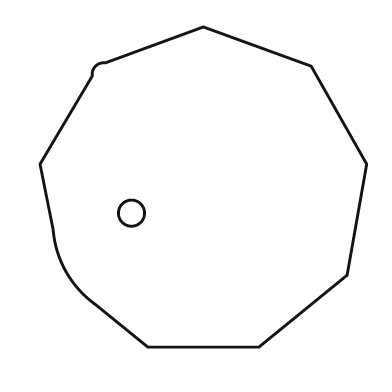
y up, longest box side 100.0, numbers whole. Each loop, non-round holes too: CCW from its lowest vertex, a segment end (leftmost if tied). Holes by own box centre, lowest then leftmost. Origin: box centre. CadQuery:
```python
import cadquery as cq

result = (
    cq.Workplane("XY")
    .moveTo(-17.0, -49.0)
    .lineTo(17.0, -49.0)
    .lineTo(44.0, -27.0)
    .lineTo(50.0, 7.0)
    .lineTo(33.0, 37.0)
    .lineTo(0.0, 49.0)
    .lineTo(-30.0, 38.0)
    .threePointArc((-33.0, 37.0), (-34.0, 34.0))
    .lineTo(-50.0, 7.0)
    .lineTo(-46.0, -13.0)
    .threePointArc((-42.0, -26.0), (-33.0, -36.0))
    .close()
    .moveTo(-22.0, -8.0)
    .circle(4.0)
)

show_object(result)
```